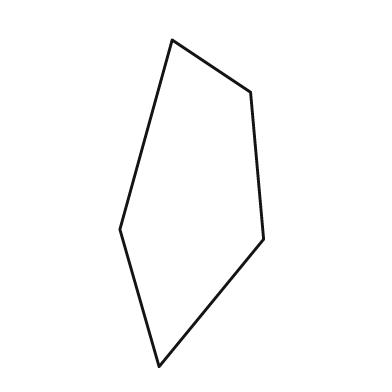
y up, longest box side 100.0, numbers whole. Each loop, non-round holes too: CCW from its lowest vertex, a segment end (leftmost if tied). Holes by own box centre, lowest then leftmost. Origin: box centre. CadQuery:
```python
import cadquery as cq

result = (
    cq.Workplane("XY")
    .moveTo(-10.0, -50.0)
    .lineTo(22.0, -11.0)
    .lineTo(18.0, 34.0)
    .lineTo(-6.0, 50.0)
    .lineTo(-22.0, -8.0)
    .close()
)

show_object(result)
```